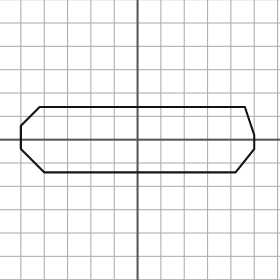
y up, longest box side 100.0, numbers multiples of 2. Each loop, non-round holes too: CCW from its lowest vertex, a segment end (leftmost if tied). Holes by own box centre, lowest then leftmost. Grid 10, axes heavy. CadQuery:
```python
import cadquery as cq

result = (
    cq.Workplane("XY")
    .moveTo(-40.0, -14.0)
    .lineTo(42.0, -14.0)
    .lineTo(50.0, -4.0)
    .lineTo(50.0, 2.0)
    .lineTo(46.0, 14.0)
    .lineTo(-42.0, 14.0)
    .lineTo(-50.0, 6.0)
    .lineTo(-50.0, -4.0)
    .close()
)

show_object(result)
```